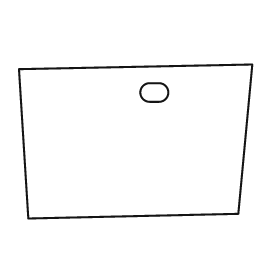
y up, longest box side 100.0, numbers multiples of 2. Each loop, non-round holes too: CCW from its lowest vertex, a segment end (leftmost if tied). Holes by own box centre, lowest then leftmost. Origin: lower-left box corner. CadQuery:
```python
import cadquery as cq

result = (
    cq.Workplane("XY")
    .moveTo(4.0, 0.0)
    .lineTo(94.0, 2.0)
    .lineTo(100.0, 66.0)
    .lineTo(0.0, 64.0)
    .close()
    .moveTo(56.0, 50.0)
    .lineTo(60.0, 50.0)
    .threePointArc((64.0, 54.0), (60.0, 58.0))
    .lineTo(56.0, 58.0)
    .threePointArc((52.0, 54.0), (56.0, 50.0))
    .close()
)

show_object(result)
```